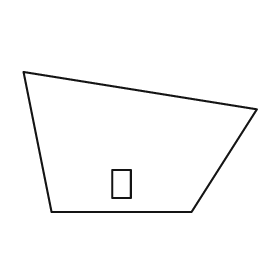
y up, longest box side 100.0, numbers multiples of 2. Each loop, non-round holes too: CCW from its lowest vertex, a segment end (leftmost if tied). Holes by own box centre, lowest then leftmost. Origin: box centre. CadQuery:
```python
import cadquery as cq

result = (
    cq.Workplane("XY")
    .moveTo(-38.0, -30.0)
    .lineTo(22.0, -30.0)
    .lineTo(50.0, 14.0)
    .lineTo(-50.0, 30.0)
    .close()
    .moveTo(-12.0, -24.0)
    .lineTo(-4.0, -24.0)
    .lineTo(-4.0, -12.0)
    .lineTo(-12.0, -12.0)
    .close()
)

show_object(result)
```